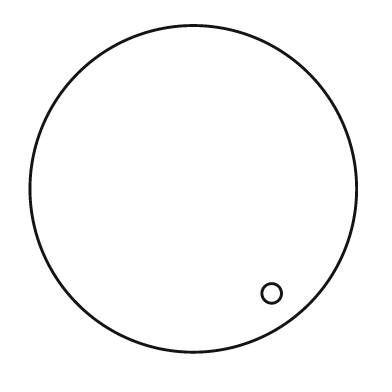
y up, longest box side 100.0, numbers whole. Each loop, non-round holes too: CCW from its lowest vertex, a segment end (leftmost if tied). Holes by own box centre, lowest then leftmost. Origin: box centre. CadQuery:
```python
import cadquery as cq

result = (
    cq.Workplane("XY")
    .moveTo(0.0, 0.0)
    .circle(50.0)
    .moveTo(24.0, -32.0)
    .circle(3.0)
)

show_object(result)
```